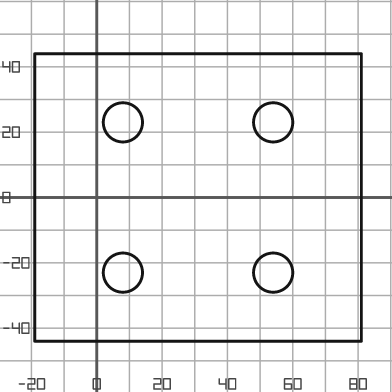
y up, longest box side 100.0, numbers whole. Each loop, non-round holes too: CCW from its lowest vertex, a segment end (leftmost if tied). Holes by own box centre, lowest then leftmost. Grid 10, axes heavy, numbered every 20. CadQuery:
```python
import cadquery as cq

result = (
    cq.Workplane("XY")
    .moveTo(-19.0, -44.0)
    .lineTo(81.0, -44.0)
    .lineTo(81.0, 44.0)
    .lineTo(-19.0, 44.0)
    .close()
    .moveTo(8.0, -23.0)
    .circle(6.0)
    .moveTo(54.0, -23.0)
    .circle(6.0)
    .moveTo(8.0, 23.0)
    .circle(6.0)
    .moveTo(54.0, 23.0)
    .circle(6.0)
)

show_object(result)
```